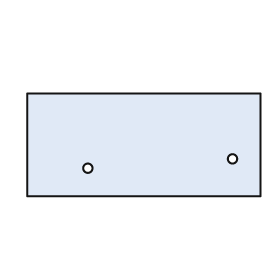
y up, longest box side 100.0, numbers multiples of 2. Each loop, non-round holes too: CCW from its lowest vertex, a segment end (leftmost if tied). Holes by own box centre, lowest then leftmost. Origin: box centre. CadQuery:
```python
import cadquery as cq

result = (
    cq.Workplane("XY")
    .moveTo(-50.0, -22.0)
    .lineTo(50.0, -22.0)
    .lineTo(50.0, 22.0)
    .lineTo(-50.0, 22.0)
    .close()
    .moveTo(-24.0, -10.0)
    .circle(2.0)
    .moveTo(38.0, -6.0)
    .circle(2.0)
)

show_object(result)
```